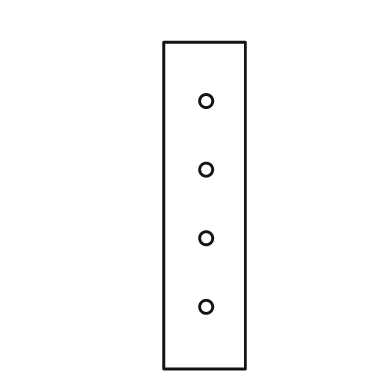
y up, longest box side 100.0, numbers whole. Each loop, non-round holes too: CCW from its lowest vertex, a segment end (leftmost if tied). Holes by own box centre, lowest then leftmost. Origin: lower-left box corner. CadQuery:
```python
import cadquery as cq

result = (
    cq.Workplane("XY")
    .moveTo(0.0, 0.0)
    .lineTo(25.0, 0.0)
    .lineTo(25.0, 100.0)
    .lineTo(0.0, 100.0)
    .close()
    .moveTo(13.0, 19.0)
    .circle(2.0)
    .moveTo(13.0, 40.0)
    .circle(2.0)
    .moveTo(13.0, 61.0)
    .circle(2.0)
    .moveTo(13.0, 82.0)
    .circle(2.0)
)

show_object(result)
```